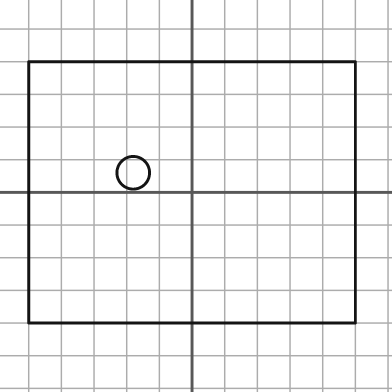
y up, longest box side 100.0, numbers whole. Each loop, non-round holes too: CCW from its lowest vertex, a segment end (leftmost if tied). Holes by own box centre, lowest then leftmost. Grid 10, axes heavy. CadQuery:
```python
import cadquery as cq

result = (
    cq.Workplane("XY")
    .moveTo(-50.0, -40.0)
    .lineTo(50.0, -40.0)
    .lineTo(50.0, 40.0)
    .lineTo(-50.0, 40.0)
    .close()
    .moveTo(-18.0, 6.0)
    .circle(5.0)
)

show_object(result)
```